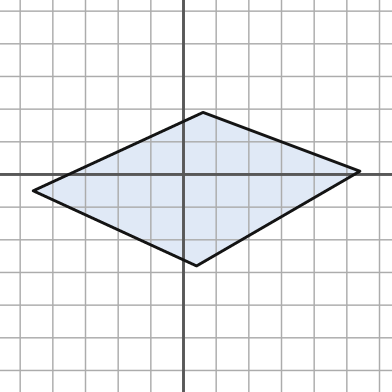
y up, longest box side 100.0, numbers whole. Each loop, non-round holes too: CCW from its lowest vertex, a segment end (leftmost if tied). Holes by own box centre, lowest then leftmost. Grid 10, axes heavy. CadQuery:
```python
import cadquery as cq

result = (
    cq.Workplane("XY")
    .moveTo(4.0, -28.0)
    .lineTo(54.0, 1.0)
    .lineTo(6.0, 19.0)
    .lineTo(-46.0, -5.0)
    .close()
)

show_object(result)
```